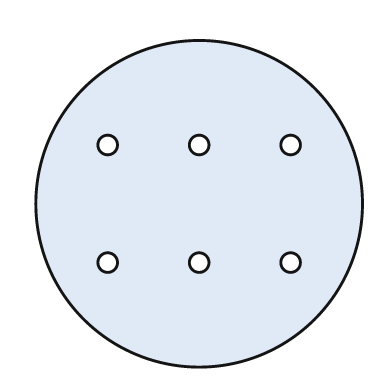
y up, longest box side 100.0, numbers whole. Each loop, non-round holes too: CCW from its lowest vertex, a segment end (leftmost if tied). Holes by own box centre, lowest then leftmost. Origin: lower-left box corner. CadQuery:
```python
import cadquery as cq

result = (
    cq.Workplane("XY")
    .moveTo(50.0, 50.0)
    .circle(50.0)
    .moveTo(22.0, 32.0)
    .circle(3.0)
    .moveTo(50.0, 32.0)
    .circle(3.0)
    .moveTo(78.0, 32.0)
    .circle(3.0)
    .moveTo(22.0, 68.0)
    .circle(3.0)
    .moveTo(50.0, 68.0)
    .circle(3.0)
    .moveTo(78.0, 68.0)
    .circle(3.0)
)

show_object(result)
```